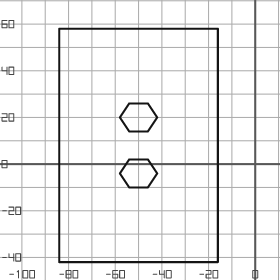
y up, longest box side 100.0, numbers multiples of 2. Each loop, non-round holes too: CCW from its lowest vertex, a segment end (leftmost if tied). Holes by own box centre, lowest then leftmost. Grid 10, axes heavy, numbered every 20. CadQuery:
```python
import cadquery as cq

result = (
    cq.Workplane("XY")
    .moveTo(-84.0, -42.0)
    .lineTo(-16.0, -42.0)
    .lineTo(-16.0, 58.0)
    .lineTo(-84.0, 58.0)
    .close()
    .moveTo(-54.0, -10.0)
    .lineTo(-46.0, -10.0)
    .lineTo(-42.0, -4.0)
    .lineTo(-46.0, 2.0)
    .lineTo(-54.0, 2.0)
    .lineTo(-58.0, -4.0)
    .close()
    .moveTo(-54.0, 14.0)
    .lineTo(-46.0, 14.0)
    .lineTo(-42.0, 20.0)
    .lineTo(-46.0, 26.0)
    .lineTo(-54.0, 26.0)
    .lineTo(-58.0, 20.0)
    .close()
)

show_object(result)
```